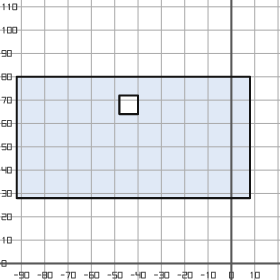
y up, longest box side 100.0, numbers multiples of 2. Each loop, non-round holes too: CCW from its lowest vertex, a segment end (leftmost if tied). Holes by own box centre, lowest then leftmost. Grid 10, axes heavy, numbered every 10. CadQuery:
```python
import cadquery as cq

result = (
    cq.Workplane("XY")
    .moveTo(-92.0, 28.0)
    .lineTo(8.0, 28.0)
    .lineTo(8.0, 80.0)
    .lineTo(-92.0, 80.0)
    .close()
    .moveTo(-48.0, 64.0)
    .lineTo(-40.0, 64.0)
    .lineTo(-40.0, 72.0)
    .lineTo(-48.0, 72.0)
    .close()
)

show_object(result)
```